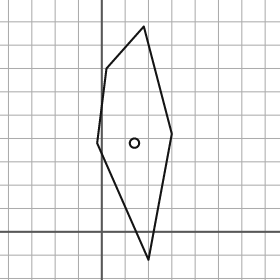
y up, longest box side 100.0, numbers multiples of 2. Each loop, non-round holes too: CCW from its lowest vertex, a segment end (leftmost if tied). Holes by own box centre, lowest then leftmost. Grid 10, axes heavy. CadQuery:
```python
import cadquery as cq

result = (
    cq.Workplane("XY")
    .moveTo(20.0, -12.0)
    .lineTo(30.0, 42.0)
    .lineTo(18.0, 88.0)
    .lineTo(2.0, 70.0)
    .lineTo(-2.0, 38.0)
    .close()
    .moveTo(14.0, 38.0)
    .circle(2.0)
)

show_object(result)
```